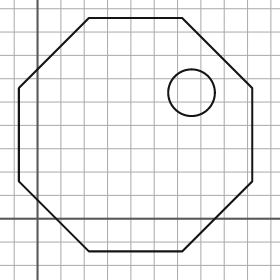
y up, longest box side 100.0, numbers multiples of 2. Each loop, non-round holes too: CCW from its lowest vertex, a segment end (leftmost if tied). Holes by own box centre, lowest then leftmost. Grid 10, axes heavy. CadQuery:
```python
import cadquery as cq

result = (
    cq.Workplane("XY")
    .moveTo(22.0, -14.0)
    .lineTo(62.0, -14.0)
    .lineTo(92.0, 16.0)
    .lineTo(92.0, 56.0)
    .lineTo(62.0, 86.0)
    .lineTo(22.0, 86.0)
    .lineTo(-8.0, 56.0)
    .lineTo(-8.0, 16.0)
    .close()
    .moveTo(66.0, 54.0)
    .circle(10.0)
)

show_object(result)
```